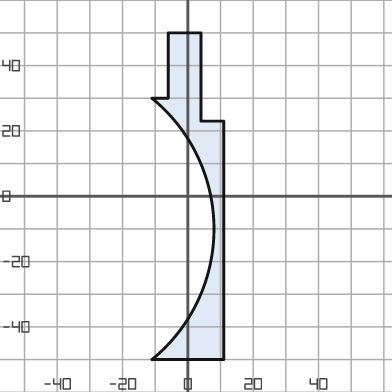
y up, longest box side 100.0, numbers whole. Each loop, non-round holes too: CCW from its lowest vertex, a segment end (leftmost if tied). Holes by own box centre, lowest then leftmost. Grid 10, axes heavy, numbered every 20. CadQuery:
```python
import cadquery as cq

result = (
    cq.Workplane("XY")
    .moveTo(-11.0, -50.0)
    .lineTo(11.0, -50.0)
    .lineTo(11.0, 23.0)
    .lineTo(4.0, 23.0)
    .lineTo(4.0, 50.0)
    .lineTo(-6.0, 50.0)
    .lineTo(-6.0, 30.0)
    .lineTo(-11.0, 30.0)
    .threePointArc((8.0, -10.0), (-11.0, -50.0))
    .close()
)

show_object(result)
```